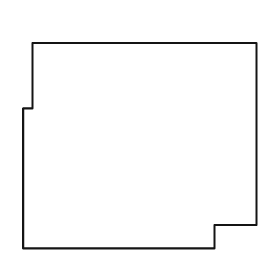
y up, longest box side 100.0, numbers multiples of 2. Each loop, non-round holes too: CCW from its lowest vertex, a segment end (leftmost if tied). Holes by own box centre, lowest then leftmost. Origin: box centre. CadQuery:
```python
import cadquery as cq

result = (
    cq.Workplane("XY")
    .moveTo(-50.0, -44.0)
    .lineTo(32.0, -44.0)
    .lineTo(32.0, -34.0)
    .lineTo(50.0, -34.0)
    .lineTo(50.0, 44.0)
    .lineTo(-46.0, 44.0)
    .lineTo(-46.0, 16.0)
    .lineTo(-50.0, 16.0)
    .close()
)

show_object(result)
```